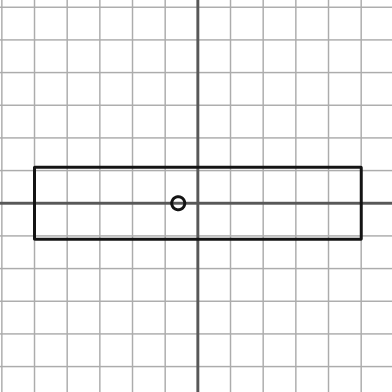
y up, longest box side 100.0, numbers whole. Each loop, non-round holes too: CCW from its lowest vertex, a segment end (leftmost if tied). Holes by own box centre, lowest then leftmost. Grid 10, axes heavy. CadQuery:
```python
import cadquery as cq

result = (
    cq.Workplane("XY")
    .moveTo(-50.0, -11.0)
    .lineTo(50.0, -11.0)
    .lineTo(50.0, 11.0)
    .lineTo(-50.0, 11.0)
    .close()
    .moveTo(-6.0, 0.0)
    .circle(2.0)
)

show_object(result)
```